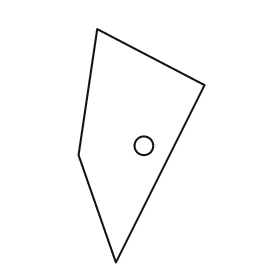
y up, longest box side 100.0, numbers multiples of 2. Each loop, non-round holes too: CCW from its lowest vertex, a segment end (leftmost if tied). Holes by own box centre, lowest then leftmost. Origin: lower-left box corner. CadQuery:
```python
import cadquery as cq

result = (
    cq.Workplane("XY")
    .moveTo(16.0, 0.0)
    .lineTo(54.0, 76.0)
    .lineTo(8.0, 100.0)
    .lineTo(0.0, 46.0)
    .close()
    .moveTo(28.0, 50.0)
    .circle(4.0)
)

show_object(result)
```